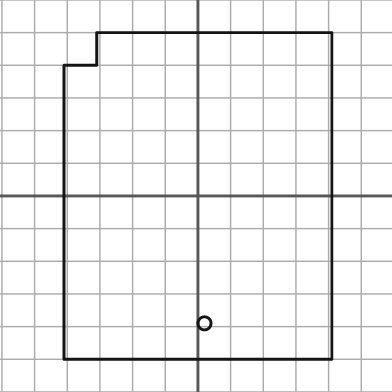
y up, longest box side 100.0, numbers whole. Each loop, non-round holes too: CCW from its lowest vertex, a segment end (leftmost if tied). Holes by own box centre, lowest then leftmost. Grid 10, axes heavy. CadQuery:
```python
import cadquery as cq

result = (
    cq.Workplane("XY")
    .moveTo(-41.0, -50.0)
    .lineTo(41.0, -50.0)
    .lineTo(41.0, 50.0)
    .lineTo(-31.0, 50.0)
    .lineTo(-31.0, 40.0)
    .lineTo(-41.0, 40.0)
    .close()
    .moveTo(2.0, -39.0)
    .circle(2.0)
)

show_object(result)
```